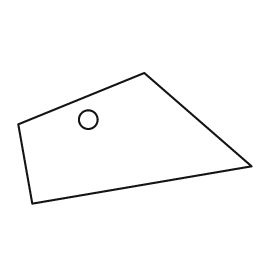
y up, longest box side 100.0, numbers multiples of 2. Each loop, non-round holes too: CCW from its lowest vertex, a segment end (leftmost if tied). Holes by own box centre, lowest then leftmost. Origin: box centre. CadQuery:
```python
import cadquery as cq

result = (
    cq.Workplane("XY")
    .moveTo(-44.0, -28.0)
    .lineTo(50.0, -12.0)
    .lineTo(4.0, 28.0)
    .lineTo(-50.0, 6.0)
    .close()
    .moveTo(-20.0, 8.0)
    .circle(4.0)
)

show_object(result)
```